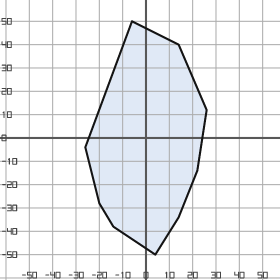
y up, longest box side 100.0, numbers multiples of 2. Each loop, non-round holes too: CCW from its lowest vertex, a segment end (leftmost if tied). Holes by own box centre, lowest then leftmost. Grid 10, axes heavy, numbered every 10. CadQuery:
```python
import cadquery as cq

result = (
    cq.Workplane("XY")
    .moveTo(4.0, -50.0)
    .lineTo(14.0, -34.0)
    .lineTo(22.0, -14.0)
    .lineTo(26.0, 12.0)
    .lineTo(14.0, 40.0)
    .lineTo(-6.0, 50.0)
    .lineTo(-26.0, -4.0)
    .lineTo(-20.0, -28.0)
    .lineTo(-14.0, -38.0)
    .close()
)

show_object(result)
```